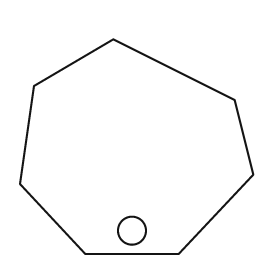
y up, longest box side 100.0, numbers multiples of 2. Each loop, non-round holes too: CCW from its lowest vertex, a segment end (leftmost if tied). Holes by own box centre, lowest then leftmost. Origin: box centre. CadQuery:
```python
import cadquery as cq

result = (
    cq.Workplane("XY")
    .moveTo(-22.0, -46.0)
    .lineTo(18.0, -46.0)
    .lineTo(50.0, -12.0)
    .lineTo(42.0, 20.0)
    .lineTo(-10.0, 46.0)
    .lineTo(-44.0, 26.0)
    .lineTo(-50.0, -16.0)
    .close()
    .moveTo(-2.0, -36.0)
    .circle(6.0)
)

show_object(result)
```